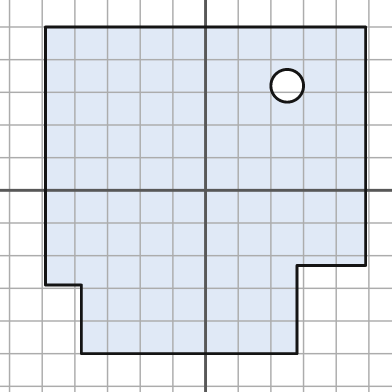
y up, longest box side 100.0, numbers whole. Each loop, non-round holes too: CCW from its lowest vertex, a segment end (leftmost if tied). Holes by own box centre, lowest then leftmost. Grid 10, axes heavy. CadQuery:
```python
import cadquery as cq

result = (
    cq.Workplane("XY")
    .moveTo(-38.0, -50.0)
    .lineTo(28.0, -50.0)
    .lineTo(28.0, -23.0)
    .lineTo(49.0, -23.0)
    .lineTo(49.0, 50.0)
    .lineTo(-49.0, 50.0)
    .lineTo(-49.0, -29.0)
    .lineTo(-38.0, -29.0)
    .close()
    .moveTo(25.0, 32.0)
    .circle(5.0)
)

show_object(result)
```